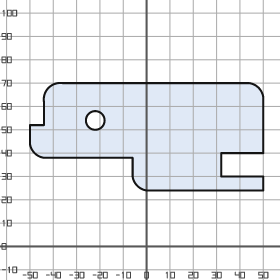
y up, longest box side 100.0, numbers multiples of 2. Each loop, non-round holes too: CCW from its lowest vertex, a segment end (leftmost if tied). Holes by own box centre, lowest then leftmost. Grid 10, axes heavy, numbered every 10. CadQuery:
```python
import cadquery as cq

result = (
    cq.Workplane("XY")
    .moveTo(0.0, 24.0)
    .lineTo(50.0, 24.0)
    .lineTo(50.0, 30.0)
    .lineTo(32.0, 30.0)
    .lineTo(32.0, 40.0)
    .lineTo(50.0, 40.0)
    .lineTo(50.0, 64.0)
    .threePointArc((48.0, 68.0), (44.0, 70.0))
    .lineTo(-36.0, 70.0)
    .threePointArc((-42.0, 68.0), (-44.0, 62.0))
    .lineTo(-44.0, 52.0)
    .lineTo(-50.0, 52.0)
    .lineTo(-50.0, 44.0)
    .threePointArc((-48.0, 40.0), (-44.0, 38.0))
    .lineTo(-6.0, 38.0)
    .lineTo(-6.0, 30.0)
    .threePointArc((-4.0, 26.0), (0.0, 24.0))
    .close()
    .moveTo(-22.0, 54.0)
    .circle(4.0)
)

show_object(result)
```